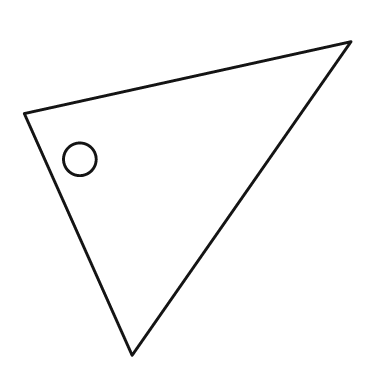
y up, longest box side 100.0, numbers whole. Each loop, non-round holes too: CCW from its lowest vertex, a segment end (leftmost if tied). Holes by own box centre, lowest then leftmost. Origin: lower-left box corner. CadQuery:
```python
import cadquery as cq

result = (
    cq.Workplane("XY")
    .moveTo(33.0, 0.0)
    .lineTo(100.0, 96.0)
    .lineTo(0.0, 74.0)
    .close()
    .moveTo(17.0, 60.0)
    .circle(5.0)
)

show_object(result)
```